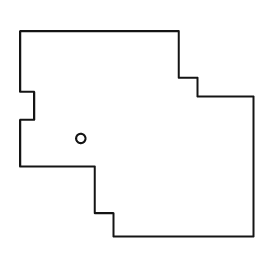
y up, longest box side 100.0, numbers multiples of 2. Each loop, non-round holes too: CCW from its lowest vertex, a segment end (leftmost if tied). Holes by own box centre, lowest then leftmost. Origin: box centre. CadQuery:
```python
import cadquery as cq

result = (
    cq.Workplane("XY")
    .moveTo(-10.0, -44.0)
    .lineTo(50.0, -44.0)
    .lineTo(50.0, 16.0)
    .lineTo(26.0, 16.0)
    .lineTo(26.0, 24.0)
    .lineTo(18.0, 24.0)
    .lineTo(18.0, 44.0)
    .lineTo(-50.0, 44.0)
    .lineTo(-50.0, 18.0)
    .lineTo(-44.0, 18.0)
    .lineTo(-44.0, 6.0)
    .lineTo(-50.0, 6.0)
    .lineTo(-50.0, -14.0)
    .lineTo(-18.0, -14.0)
    .lineTo(-18.0, -34.0)
    .lineTo(-10.0, -34.0)
    .close()
    .moveTo(-24.0, -2.0)
    .circle(2.0)
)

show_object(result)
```